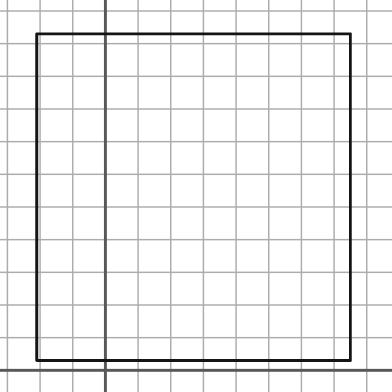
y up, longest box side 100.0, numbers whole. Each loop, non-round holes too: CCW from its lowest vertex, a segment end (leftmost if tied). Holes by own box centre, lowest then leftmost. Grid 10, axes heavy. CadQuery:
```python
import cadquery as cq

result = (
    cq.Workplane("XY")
    .moveTo(-21.0, 3.0)
    .lineTo(75.0, 3.0)
    .lineTo(75.0, 103.0)
    .lineTo(-21.0, 103.0)
    .close()
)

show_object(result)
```